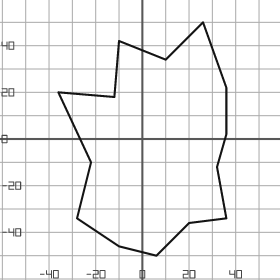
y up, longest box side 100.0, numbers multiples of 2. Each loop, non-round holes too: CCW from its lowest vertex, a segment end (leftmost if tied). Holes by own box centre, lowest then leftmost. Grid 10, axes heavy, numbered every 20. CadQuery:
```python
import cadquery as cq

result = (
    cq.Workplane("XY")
    .moveTo(6.0, -50.0)
    .lineTo(20.0, -36.0)
    .lineTo(36.0, -34.0)
    .lineTo(32.0, -12.0)
    .lineTo(36.0, 2.0)
    .lineTo(36.0, 22.0)
    .lineTo(26.0, 50.0)
    .lineTo(10.0, 34.0)
    .lineTo(-10.0, 42.0)
    .lineTo(-12.0, 18.0)
    .lineTo(-36.0, 20.0)
    .lineTo(-22.0, -10.0)
    .lineTo(-28.0, -34.0)
    .lineTo(-10.0, -46.0)
    .close()
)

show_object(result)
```